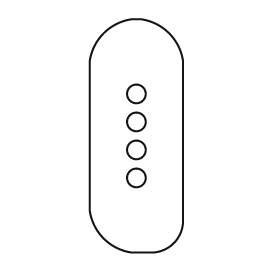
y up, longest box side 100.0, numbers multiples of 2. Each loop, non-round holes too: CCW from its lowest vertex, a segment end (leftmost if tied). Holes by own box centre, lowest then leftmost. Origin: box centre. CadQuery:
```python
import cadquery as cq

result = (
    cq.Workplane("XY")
    .moveTo(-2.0, -50.0)
    .lineTo(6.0, -50.0)
    .threePointArc((16.0, -46.0), (20.0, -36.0))
    .lineTo(20.0, 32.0)
    .threePointArc((14.0, 44.0), (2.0, 50.0))
    .lineTo(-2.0, 50.0)
    .threePointArc((-14.0, 44.0), (-20.0, 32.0))
    .lineTo(-20.0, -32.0)
    .threePointArc((-14.0, -44.0), (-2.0, -50.0))
    .close()
    .moveTo(0.0, -18.0)
    .circle(4.0)
    .moveTo(0.0, -6.0)
    .circle(4.0)
    .moveTo(0.0, 6.0)
    .circle(4.0)
    .moveTo(0.0, 18.0)
    .circle(4.0)
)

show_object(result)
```